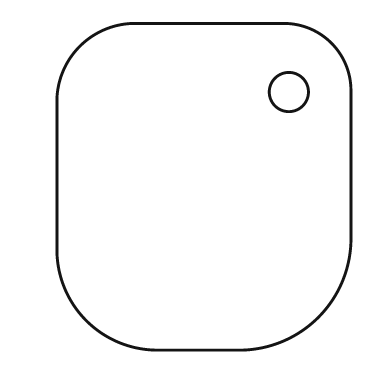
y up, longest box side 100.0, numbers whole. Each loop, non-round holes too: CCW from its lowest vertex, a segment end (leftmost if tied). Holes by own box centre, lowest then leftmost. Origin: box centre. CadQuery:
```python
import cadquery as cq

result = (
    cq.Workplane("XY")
    .moveTo(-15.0, -50.0)
    .lineTo(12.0, -50.0)
    .threePointArc((35.0, -40.0), (45.0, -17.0))
    .lineTo(45.0, 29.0)
    .threePointArc((39.0, 44.0), (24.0, 50.0))
    .lineTo(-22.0, 50.0)
    .threePointArc((-38.0, 43.0), (-45.0, 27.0))
    .lineTo(-45.0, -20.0)
    .threePointArc((-36.0, -41.0), (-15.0, -50.0))
    .close()
    .moveTo(26.0, 29.0)
    .circle(6.0)
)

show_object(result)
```